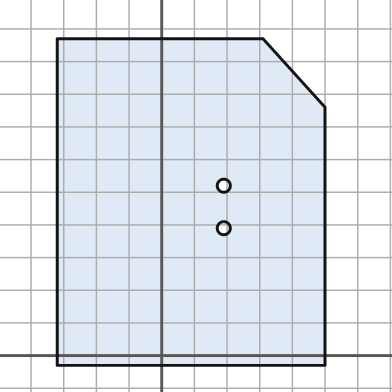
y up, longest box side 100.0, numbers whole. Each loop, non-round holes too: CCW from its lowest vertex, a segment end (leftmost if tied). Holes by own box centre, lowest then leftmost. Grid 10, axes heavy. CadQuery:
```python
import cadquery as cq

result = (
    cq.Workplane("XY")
    .moveTo(-32.0, -3.0)
    .lineTo(50.0, -3.0)
    .lineTo(50.0, 76.0)
    .lineTo(31.0, 97.0)
    .lineTo(-32.0, 97.0)
    .close()
    .moveTo(19.0, 39.0)
    .circle(2.0)
    .moveTo(19.0, 52.0)
    .circle(2.0)
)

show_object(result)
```